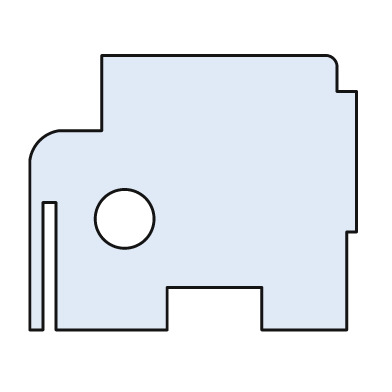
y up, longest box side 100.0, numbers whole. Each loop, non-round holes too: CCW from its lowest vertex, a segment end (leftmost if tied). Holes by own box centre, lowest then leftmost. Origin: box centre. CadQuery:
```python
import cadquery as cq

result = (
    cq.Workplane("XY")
    .moveTo(-50.0, -42.0)
    .lineTo(-46.0, -42.0)
    .lineTo(-46.0, -3.0)
    .lineTo(-42.0, -3.0)
    .lineTo(-42.0, -42.0)
    .lineTo(-8.0, -42.0)
    .lineTo(-8.0, -29.0)
    .lineTo(21.0, -29.0)
    .lineTo(21.0, -42.0)
    .lineTo(47.0, -42.0)
    .lineTo(47.0, -12.0)
    .lineTo(50.0, -12.0)
    .lineTo(50.0, 31.0)
    .lineTo(44.0, 31.0)
    .lineTo(44.0, 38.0)
    .threePointArc((43.0, 41.0), (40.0, 42.0))
    .lineTo(-28.0, 42.0)
    .lineTo(-28.0, 19.0)
    .lineTo(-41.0, 19.0)
    .threePointArc((-47.0, 16.0), (-50.0, 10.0))
    .close()
    .moveTo(-21.0, -8.0)
    .circle(9.0)
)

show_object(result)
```